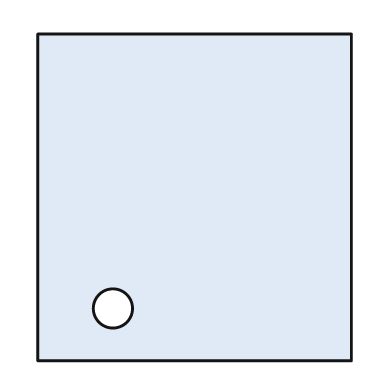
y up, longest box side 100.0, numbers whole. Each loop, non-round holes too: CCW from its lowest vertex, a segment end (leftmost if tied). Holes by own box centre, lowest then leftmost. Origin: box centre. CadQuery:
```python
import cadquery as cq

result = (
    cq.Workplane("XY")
    .moveTo(-48.0, -50.0)
    .lineTo(48.0, -50.0)
    .lineTo(48.0, 50.0)
    .lineTo(-48.0, 50.0)
    .close()
    .moveTo(-25.0, -34.0)
    .circle(6.0)
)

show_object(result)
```